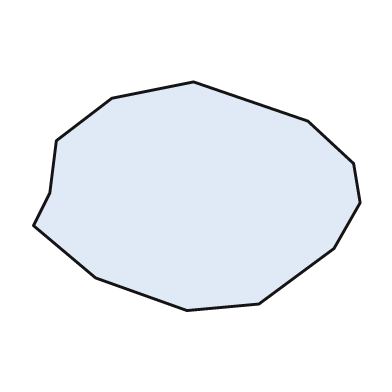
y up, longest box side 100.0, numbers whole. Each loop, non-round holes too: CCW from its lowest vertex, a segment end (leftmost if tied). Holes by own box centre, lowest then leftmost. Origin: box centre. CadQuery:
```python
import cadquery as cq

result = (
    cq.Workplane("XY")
    .moveTo(-3.0, -35.0)
    .lineTo(19.0, -33.0)
    .lineTo(42.0, -16.0)
    .lineTo(50.0, -2.0)
    .lineTo(48.0, 10.0)
    .lineTo(34.0, 23.0)
    .lineTo(-1.0, 35.0)
    .lineTo(-26.0, 30.0)
    .lineTo(-43.0, 17.0)
    .lineTo(-45.0, 1.0)
    .lineTo(-50.0, -9.0)
    .lineTo(-31.0, -25.0)
    .close()
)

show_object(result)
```